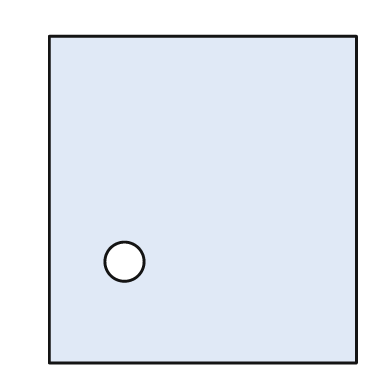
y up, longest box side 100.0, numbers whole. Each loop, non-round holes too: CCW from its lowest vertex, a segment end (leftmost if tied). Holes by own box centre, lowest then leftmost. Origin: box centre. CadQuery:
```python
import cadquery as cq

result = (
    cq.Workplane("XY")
    .moveTo(-47.0, -50.0)
    .lineTo(47.0, -50.0)
    .lineTo(47.0, 50.0)
    .lineTo(-47.0, 50.0)
    .close()
    .moveTo(-24.0, -19.0)
    .circle(6.0)
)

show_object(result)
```